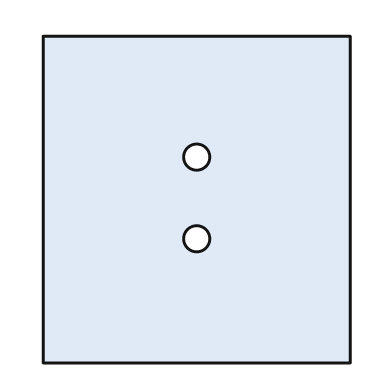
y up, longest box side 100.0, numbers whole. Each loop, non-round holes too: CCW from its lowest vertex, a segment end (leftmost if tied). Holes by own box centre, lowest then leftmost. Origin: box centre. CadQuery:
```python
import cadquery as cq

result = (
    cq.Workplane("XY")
    .moveTo(-47.0, -50.0)
    .lineTo(47.0, -50.0)
    .lineTo(47.0, 50.0)
    .lineTo(-47.0, 50.0)
    .close()
    .moveTo(0.0, -12.0)
    .circle(4.0)
    .moveTo(0.0, 13.0)
    .circle(4.0)
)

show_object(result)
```